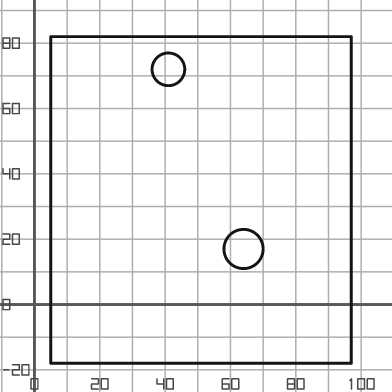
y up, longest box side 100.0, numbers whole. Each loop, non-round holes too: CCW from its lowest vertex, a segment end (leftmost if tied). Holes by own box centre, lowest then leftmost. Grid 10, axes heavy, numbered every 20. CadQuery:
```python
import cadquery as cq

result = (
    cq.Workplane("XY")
    .moveTo(5.0, -18.0)
    .lineTo(97.0, -18.0)
    .lineTo(97.0, 82.0)
    .lineTo(5.0, 82.0)
    .close()
    .moveTo(64.0, 17.0)
    .circle(6.0)
    .moveTo(41.0, 72.0)
    .circle(5.0)
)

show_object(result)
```